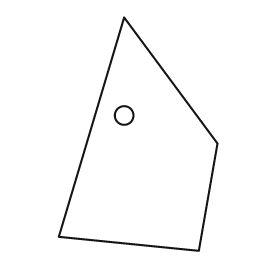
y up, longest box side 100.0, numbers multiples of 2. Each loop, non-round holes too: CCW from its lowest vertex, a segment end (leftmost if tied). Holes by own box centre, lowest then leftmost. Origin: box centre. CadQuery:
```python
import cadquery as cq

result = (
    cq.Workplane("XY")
    .moveTo(26.0, -50.0)
    .lineTo(34.0, -4.0)
    .lineTo(-6.0, 50.0)
    .lineTo(-34.0, -44.0)
    .close()
    .moveTo(-6.0, 8.0)
    .circle(4.0)
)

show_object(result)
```